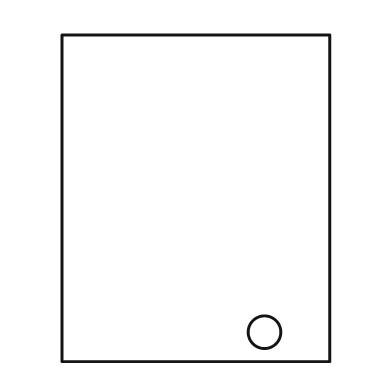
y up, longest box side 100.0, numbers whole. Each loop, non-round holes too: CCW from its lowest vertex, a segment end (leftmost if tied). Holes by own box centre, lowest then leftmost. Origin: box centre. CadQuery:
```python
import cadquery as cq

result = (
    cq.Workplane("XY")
    .moveTo(-41.0, -50.0)
    .lineTo(41.0, -50.0)
    .lineTo(41.0, 50.0)
    .lineTo(-41.0, 50.0)
    .close()
    .moveTo(21.0, -41.0)
    .circle(5.0)
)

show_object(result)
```